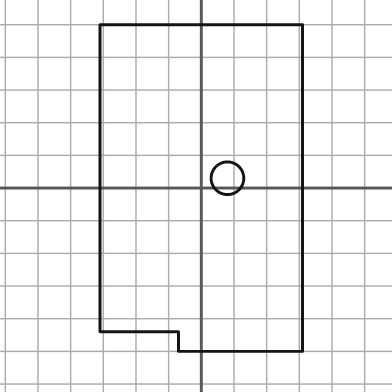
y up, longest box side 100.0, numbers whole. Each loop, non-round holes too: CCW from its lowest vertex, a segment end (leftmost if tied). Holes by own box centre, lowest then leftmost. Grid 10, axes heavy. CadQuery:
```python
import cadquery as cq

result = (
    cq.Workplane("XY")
    .moveTo(-7.0, -50.0)
    .lineTo(31.0, -50.0)
    .lineTo(31.0, 50.0)
    .lineTo(-31.0, 50.0)
    .lineTo(-31.0, -44.0)
    .lineTo(-7.0, -44.0)
    .close()
    .moveTo(8.0, 3.0)
    .circle(5.0)
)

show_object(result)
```